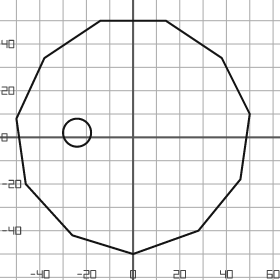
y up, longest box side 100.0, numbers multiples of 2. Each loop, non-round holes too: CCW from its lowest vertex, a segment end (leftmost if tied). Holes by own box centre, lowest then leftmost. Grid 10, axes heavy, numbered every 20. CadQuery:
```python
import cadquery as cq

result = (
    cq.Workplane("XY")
    .moveTo(0.0, -50.0)
    .lineTo(28.0, -40.0)
    .lineTo(46.0, -18.0)
    .lineTo(50.0, 10.0)
    .lineTo(38.0, 34.0)
    .lineTo(14.0, 50.0)
    .lineTo(-14.0, 50.0)
    .lineTo(-38.0, 34.0)
    .lineTo(-50.0, 8.0)
    .lineTo(-46.0, -20.0)
    .lineTo(-26.0, -42.0)
    .close()
    .moveTo(-24.0, 2.0)
    .circle(6.0)
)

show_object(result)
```